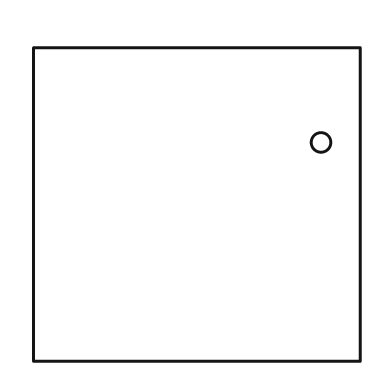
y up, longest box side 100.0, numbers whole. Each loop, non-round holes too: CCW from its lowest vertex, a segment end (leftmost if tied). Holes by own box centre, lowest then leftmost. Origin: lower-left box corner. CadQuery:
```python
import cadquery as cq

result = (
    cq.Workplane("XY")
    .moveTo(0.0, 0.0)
    .lineTo(100.0, 0.0)
    .lineTo(100.0, 96.0)
    .lineTo(0.0, 96.0)
    .close()
    .moveTo(88.0, 67.0)
    .circle(3.0)
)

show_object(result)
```